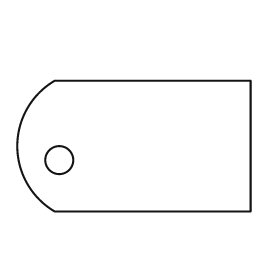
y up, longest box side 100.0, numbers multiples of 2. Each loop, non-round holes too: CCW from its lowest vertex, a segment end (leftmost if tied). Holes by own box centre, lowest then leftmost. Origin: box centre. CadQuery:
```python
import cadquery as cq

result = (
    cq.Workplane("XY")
    .moveTo(-34.0, -28.0)
    .lineTo(50.0, -28.0)
    .lineTo(50.0, 28.0)
    .lineTo(-34.0, 28.0)
    .threePointArc((-50.0, 0.0), (-34.0, -28.0))
    .close()
    .moveTo(-32.0, -6.0)
    .circle(6.0)
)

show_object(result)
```